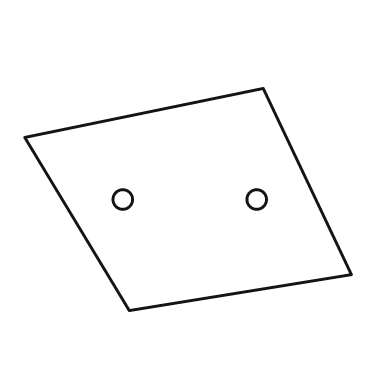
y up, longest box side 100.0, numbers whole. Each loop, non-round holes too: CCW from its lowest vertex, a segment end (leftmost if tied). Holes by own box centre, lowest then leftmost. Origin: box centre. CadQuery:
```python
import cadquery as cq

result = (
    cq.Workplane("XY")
    .moveTo(-18.0, -34.0)
    .lineTo(50.0, -23.0)
    .lineTo(23.0, 34.0)
    .lineTo(-50.0, 19.0)
    .close()
    .moveTo(-20.0, 0.0)
    .circle(3.0)
    .moveTo(21.0, 0.0)
    .circle(3.0)
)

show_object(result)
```